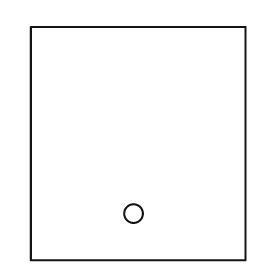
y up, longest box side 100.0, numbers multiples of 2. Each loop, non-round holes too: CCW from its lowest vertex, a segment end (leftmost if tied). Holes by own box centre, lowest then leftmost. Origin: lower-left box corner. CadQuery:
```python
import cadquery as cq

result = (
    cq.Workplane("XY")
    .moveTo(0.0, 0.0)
    .lineTo(92.0, 0.0)
    .lineTo(92.0, 100.0)
    .lineTo(0.0, 100.0)
    .close()
    .moveTo(44.0, 20.0)
    .circle(4.0)
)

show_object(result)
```